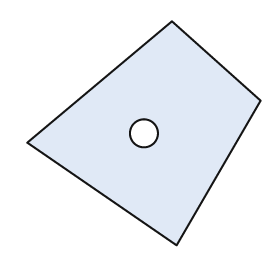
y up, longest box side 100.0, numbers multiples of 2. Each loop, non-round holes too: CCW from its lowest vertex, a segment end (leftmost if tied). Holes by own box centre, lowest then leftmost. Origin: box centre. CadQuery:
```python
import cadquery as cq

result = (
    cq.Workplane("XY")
    .moveTo(14.0, -48.0)
    .lineTo(50.0, 14.0)
    .lineTo(12.0, 48.0)
    .lineTo(-50.0, -4.0)
    .close()
    .moveTo(0.0, 0.0)
    .circle(6.0)
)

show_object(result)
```